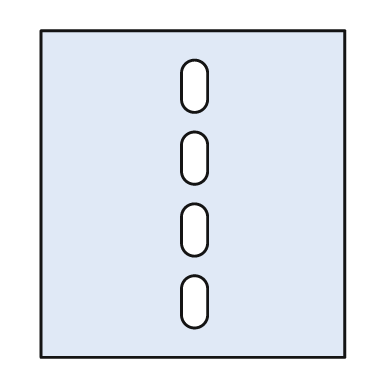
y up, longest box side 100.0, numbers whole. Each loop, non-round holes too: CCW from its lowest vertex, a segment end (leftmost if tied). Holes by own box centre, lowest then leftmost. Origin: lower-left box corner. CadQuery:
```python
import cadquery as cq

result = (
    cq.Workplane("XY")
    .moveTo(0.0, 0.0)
    .lineTo(93.0, 0.0)
    .lineTo(93.0, 100.0)
    .lineTo(0.0, 100.0)
    .close()
    .moveTo(43.0, 13.0)
    .threePointArc((47.0, 9.0), (51.0, 13.0))
    .lineTo(51.0, 21.0)
    .threePointArc((47.0, 25.0), (43.0, 21.0))
    .close()
    .moveTo(43.0, 35.0)
    .threePointArc((47.0, 31.0), (51.0, 35.0))
    .lineTo(51.0, 43.0)
    .threePointArc((47.0, 47.0), (43.0, 43.0))
    .close()
    .moveTo(43.0, 57.0)
    .threePointArc((47.0, 53.0), (51.0, 57.0))
    .lineTo(51.0, 65.0)
    .threePointArc((47.0, 69.0), (43.0, 65.0))
    .close()
    .moveTo(43.0, 79.0)
    .threePointArc((47.0, 75.0), (51.0, 79.0))
    .lineTo(51.0, 87.0)
    .threePointArc((47.0, 91.0), (43.0, 87.0))
    .close()
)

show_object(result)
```